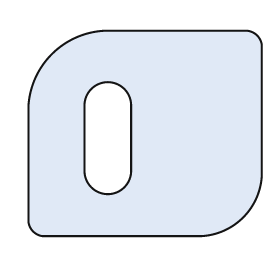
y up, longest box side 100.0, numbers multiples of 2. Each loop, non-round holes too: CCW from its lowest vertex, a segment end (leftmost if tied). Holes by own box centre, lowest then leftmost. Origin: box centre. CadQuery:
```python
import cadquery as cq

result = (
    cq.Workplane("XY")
    .moveTo(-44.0, -44.0)
    .lineTo(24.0, -44.0)
    .threePointArc((42.0, -36.0), (50.0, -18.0))
    .lineTo(50.0, 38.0)
    .threePointArc((48.0, 42.0), (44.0, 44.0))
    .lineTo(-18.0, 44.0)
    .threePointArc((-40.0, 34.0), (-50.0, 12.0))
    .lineTo(-50.0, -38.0)
    .threePointArc((-48.0, -42.0), (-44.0, -44.0))
    .close()
    .moveTo(-26.0, -16.0)
    .threePointArc((-16.0, -26.0), (-6.0, -16.0))
    .lineTo(-6.0, 12.0)
    .threePointArc((-16.0, 22.0), (-26.0, 12.0))
    .close()
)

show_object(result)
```